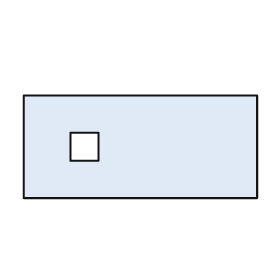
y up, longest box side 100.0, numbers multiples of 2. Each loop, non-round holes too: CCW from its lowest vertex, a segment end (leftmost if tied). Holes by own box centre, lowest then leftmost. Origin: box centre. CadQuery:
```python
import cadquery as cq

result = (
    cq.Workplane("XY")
    .moveTo(-50.0, -22.0)
    .lineTo(50.0, -22.0)
    .lineTo(50.0, 22.0)
    .lineTo(-50.0, 22.0)
    .close()
    .moveTo(-30.0, -6.0)
    .lineTo(-18.0, -6.0)
    .lineTo(-18.0, 6.0)
    .lineTo(-30.0, 6.0)
    .close()
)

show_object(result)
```